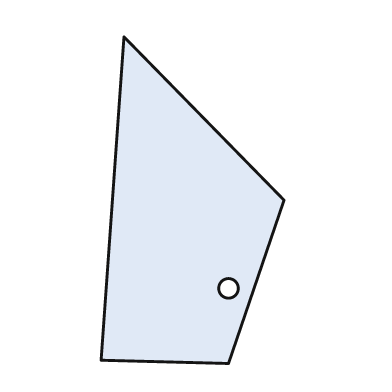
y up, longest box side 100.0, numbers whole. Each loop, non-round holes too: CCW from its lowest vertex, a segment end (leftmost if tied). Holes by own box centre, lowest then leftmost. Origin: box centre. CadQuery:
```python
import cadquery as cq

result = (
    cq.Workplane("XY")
    .moveTo(11.0, -50.0)
    .lineTo(28.0, 0.0)
    .lineTo(-21.0, 50.0)
    .lineTo(-28.0, -49.0)
    .close()
    .moveTo(11.0, -27.0)
    .circle(3.0)
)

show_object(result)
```